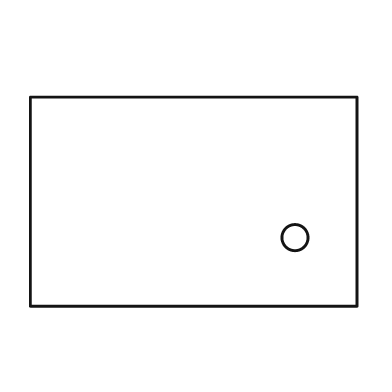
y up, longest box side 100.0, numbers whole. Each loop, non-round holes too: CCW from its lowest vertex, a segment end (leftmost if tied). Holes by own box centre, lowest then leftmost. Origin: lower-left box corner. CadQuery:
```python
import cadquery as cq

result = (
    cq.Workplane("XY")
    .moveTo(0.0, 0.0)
    .lineTo(100.0, 0.0)
    .lineTo(100.0, 64.0)
    .lineTo(0.0, 64.0)
    .close()
    .moveTo(81.0, 21.0)
    .circle(4.0)
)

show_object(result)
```